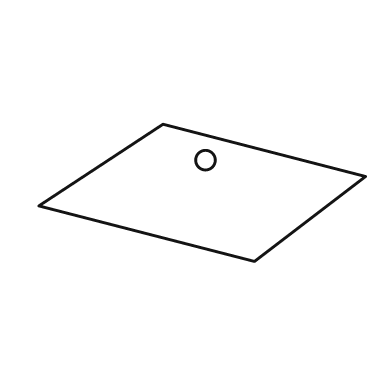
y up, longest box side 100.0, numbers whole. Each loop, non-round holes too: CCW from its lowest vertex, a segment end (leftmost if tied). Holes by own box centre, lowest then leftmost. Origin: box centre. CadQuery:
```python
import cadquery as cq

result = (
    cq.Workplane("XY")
    .moveTo(16.0, -21.0)
    .lineTo(50.0, 5.0)
    .lineTo(-12.0, 21.0)
    .lineTo(-50.0, -4.0)
    .close()
    .moveTo(1.0, 10.0)
    .circle(3.0)
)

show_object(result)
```